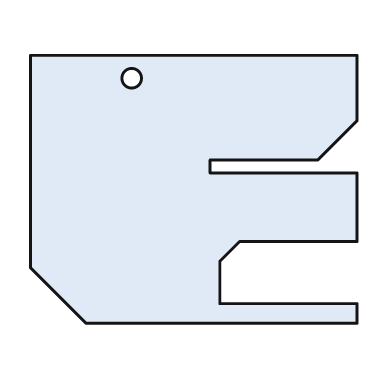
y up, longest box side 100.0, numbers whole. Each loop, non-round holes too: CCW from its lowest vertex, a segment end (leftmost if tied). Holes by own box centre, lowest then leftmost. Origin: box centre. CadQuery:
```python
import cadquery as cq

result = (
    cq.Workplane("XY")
    .moveTo(-33.0, -41.0)
    .lineTo(50.0, -41.0)
    .lineTo(50.0, -35.0)
    .lineTo(8.0, -35.0)
    .lineTo(8.0, -22.0)
    .lineTo(14.0, -16.0)
    .lineTo(50.0, -16.0)
    .lineTo(50.0, 5.0)
    .lineTo(5.0, 5.0)
    .lineTo(5.0, 9.0)
    .lineTo(38.0, 9.0)
    .lineTo(50.0, 21.0)
    .lineTo(50.0, 41.0)
    .lineTo(-50.0, 41.0)
    .lineTo(-50.0, -24.0)
    .close()
    .moveTo(-19.0, 34.0)
    .circle(3.0)
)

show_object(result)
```